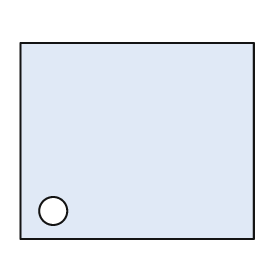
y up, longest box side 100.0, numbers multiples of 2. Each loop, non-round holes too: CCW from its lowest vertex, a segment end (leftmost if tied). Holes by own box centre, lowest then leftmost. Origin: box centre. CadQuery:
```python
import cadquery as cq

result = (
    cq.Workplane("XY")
    .moveTo(-50.0, -42.0)
    .lineTo(50.0, -42.0)
    .lineTo(50.0, 42.0)
    .lineTo(-50.0, 42.0)
    .close()
    .moveTo(-36.0, -30.0)
    .circle(6.0)
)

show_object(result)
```